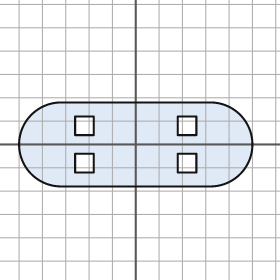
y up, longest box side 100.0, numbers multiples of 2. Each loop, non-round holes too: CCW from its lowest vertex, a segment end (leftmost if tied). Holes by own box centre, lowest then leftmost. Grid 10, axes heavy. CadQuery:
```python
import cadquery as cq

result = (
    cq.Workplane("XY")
    .moveTo(-32.0, -18.0)
    .lineTo(32.0, -18.0)
    .threePointArc((50.0, 0.0), (32.0, 18.0))
    .lineTo(-32.0, 18.0)
    .threePointArc((-50.0, 0.0), (-32.0, -18.0))
    .close()
    .moveTo(-26.0, -12.0)
    .lineTo(-18.0, -12.0)
    .lineTo(-18.0, -4.0)
    .lineTo(-26.0, -4.0)
    .close()
    .moveTo(18.0, -12.0)
    .lineTo(26.0, -12.0)
    .lineTo(26.0, -4.0)
    .lineTo(18.0, -4.0)
    .close()
    .moveTo(-26.0, 4.0)
    .lineTo(-18.0, 4.0)
    .lineTo(-18.0, 12.0)
    .lineTo(-26.0, 12.0)
    .close()
    .moveTo(18.0, 4.0)
    .lineTo(26.0, 4.0)
    .lineTo(26.0, 12.0)
    .lineTo(18.0, 12.0)
    .close()
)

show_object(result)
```